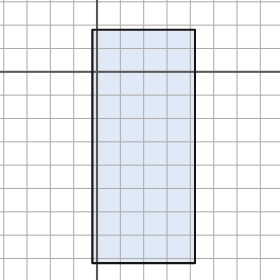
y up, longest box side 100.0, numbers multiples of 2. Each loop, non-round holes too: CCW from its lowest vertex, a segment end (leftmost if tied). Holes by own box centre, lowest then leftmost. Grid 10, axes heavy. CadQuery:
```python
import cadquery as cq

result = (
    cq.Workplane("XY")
    .moveTo(-2.0, -82.0)
    .lineTo(42.0, -82.0)
    .lineTo(42.0, 18.0)
    .lineTo(-2.0, 18.0)
    .close()
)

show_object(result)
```